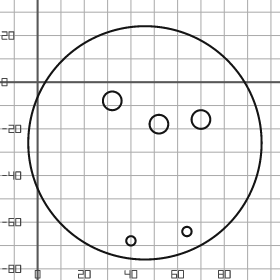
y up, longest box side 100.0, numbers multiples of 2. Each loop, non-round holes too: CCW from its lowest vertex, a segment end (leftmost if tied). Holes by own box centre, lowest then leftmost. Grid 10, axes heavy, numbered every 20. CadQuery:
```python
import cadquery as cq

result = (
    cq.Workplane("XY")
    .moveTo(46.0, -26.0)
    .circle(50.0)
    .moveTo(40.0, -68.0)
    .circle(2.0)
    .moveTo(64.0, -64.0)
    .circle(2.0)
    .moveTo(52.0, -18.0)
    .circle(4.0)
    .moveTo(70.0, -16.0)
    .circle(4.0)
    .moveTo(32.0, -8.0)
    .circle(4.0)
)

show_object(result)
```